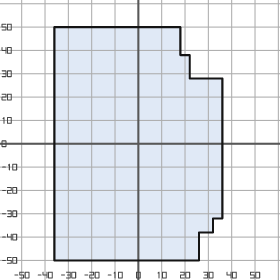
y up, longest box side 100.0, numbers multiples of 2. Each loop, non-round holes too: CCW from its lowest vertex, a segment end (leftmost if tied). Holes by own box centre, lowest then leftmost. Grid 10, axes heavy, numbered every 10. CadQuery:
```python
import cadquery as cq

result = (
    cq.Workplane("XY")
    .moveTo(-36.0, -50.0)
    .lineTo(26.0, -50.0)
    .lineTo(26.0, -38.0)
    .lineTo(32.0, -38.0)
    .lineTo(32.0, -32.0)
    .lineTo(36.0, -32.0)
    .lineTo(36.0, 28.0)
    .lineTo(22.0, 28.0)
    .lineTo(22.0, 38.0)
    .lineTo(18.0, 38.0)
    .lineTo(18.0, 50.0)
    .lineTo(-36.0, 50.0)
    .close()
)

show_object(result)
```